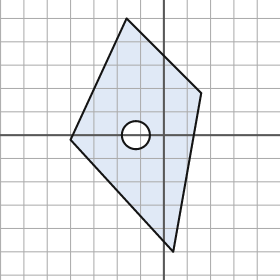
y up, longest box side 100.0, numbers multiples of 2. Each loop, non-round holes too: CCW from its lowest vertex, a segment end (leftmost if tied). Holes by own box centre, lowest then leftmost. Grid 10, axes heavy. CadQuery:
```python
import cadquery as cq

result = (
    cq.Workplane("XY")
    .moveTo(4.0, -50.0)
    .lineTo(16.0, 18.0)
    .lineTo(-16.0, 50.0)
    .lineTo(-40.0, -2.0)
    .close()
    .moveTo(-12.0, 0.0)
    .circle(6.0)
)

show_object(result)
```